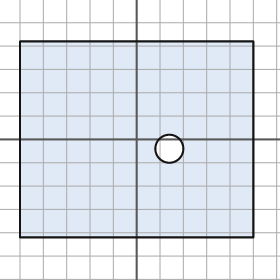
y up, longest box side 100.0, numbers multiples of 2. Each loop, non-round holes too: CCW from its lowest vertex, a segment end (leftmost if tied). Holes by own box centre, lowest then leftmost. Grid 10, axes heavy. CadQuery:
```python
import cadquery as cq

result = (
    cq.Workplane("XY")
    .moveTo(-50.0, -42.0)
    .lineTo(50.0, -42.0)
    .lineTo(50.0, 42.0)
    .lineTo(-50.0, 42.0)
    .close()
    .moveTo(14.0, -4.0)
    .circle(6.0)
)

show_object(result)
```